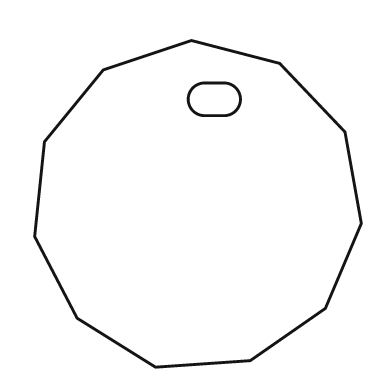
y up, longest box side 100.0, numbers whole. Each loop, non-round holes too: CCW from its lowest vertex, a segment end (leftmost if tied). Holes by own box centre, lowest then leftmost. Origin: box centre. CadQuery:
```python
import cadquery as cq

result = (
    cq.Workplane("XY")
    .moveTo(-13.0, -50.0)
    .lineTo(16.0, -48.0)
    .lineTo(39.0, -32.0)
    .lineTo(50.0, -6.0)
    .lineTo(45.0, 22.0)
    .lineTo(25.0, 43.0)
    .lineTo(-2.0, 50.0)
    .lineTo(-29.0, 41.0)
    .lineTo(-47.0, 19.0)
    .lineTo(-50.0, -10.0)
    .lineTo(-37.0, -35.0)
    .close()
    .moveTo(2.0, 27.0)
    .lineTo(8.0, 27.0)
    .threePointArc((13.0, 32.0), (8.0, 37.0))
    .lineTo(2.0, 37.0)
    .threePointArc((-3.0, 32.0), (2.0, 27.0))
    .close()
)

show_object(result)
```